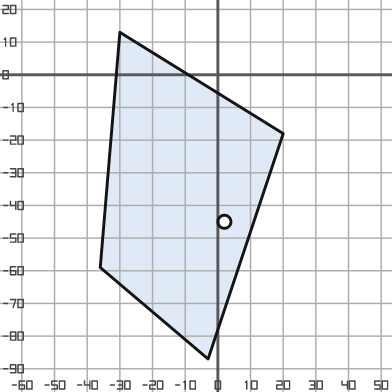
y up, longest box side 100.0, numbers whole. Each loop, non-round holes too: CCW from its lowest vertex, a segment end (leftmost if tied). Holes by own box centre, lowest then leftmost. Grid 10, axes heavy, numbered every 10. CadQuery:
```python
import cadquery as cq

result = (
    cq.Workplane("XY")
    .moveTo(-3.0, -87.0)
    .lineTo(20.0, -18.0)
    .lineTo(-30.0, 13.0)
    .lineTo(-36.0, -59.0)
    .close()
    .moveTo(2.0, -45.0)
    .circle(2.0)
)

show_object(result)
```